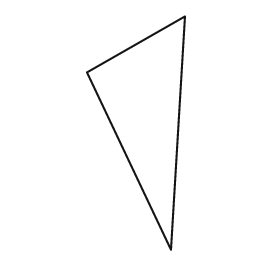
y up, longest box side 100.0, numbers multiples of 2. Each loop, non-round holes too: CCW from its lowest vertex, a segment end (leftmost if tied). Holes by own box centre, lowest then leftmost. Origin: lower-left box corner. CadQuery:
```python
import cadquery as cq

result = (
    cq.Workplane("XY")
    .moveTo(36.0, 0.0)
    .lineTo(42.0, 100.0)
    .lineTo(0.0, 76.0)
    .close()
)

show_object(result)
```